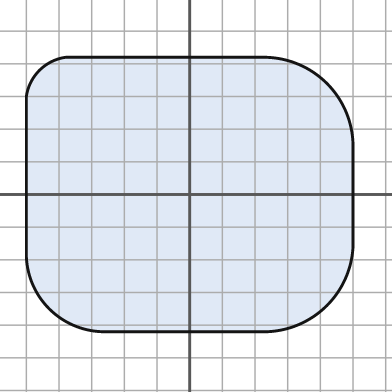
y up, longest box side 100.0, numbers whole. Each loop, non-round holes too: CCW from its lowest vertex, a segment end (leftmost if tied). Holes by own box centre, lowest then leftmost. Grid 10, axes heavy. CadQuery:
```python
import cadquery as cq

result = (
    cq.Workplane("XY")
    .moveTo(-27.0, -42.0)
    .lineTo(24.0, -42.0)
    .threePointArc((42.0, -34.0), (50.0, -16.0))
    .lineTo(50.0, 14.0)
    .threePointArc((42.0, 34.0), (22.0, 42.0))
    .lineTo(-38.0, 42.0)
    .threePointArc((-46.0, 38.0), (-50.0, 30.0))
    .lineTo(-50.0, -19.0)
    .threePointArc((-43.0, -35.0), (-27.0, -42.0))
    .close()
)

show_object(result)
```